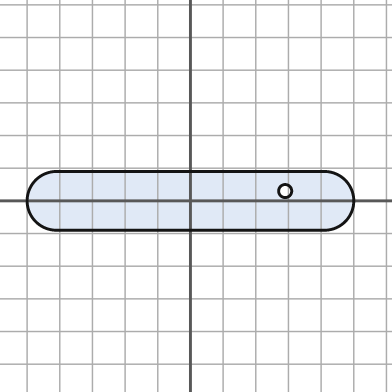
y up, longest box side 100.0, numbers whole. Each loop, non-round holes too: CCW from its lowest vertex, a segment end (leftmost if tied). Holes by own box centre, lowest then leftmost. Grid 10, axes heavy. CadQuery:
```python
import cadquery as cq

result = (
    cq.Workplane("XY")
    .moveTo(-41.0, -9.0)
    .lineTo(41.0, -9.0)
    .threePointArc((50.0, 0.0), (41.0, 9.0))
    .lineTo(-41.0, 9.0)
    .threePointArc((-50.0, 0.0), (-41.0, -9.0))
    .close()
    .moveTo(29.0, 3.0)
    .circle(2.0)
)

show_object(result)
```